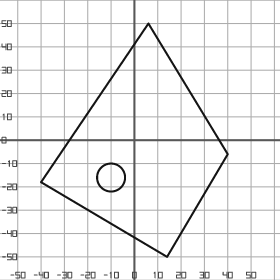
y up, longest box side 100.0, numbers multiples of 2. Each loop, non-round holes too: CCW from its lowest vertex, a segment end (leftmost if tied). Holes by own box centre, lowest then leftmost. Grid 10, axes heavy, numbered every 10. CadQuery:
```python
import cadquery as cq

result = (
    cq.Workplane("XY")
    .moveTo(14.0, -50.0)
    .lineTo(40.0, -6.0)
    .lineTo(6.0, 50.0)
    .lineTo(-40.0, -18.0)
    .close()
    .moveTo(-10.0, -16.0)
    .circle(6.0)
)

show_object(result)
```